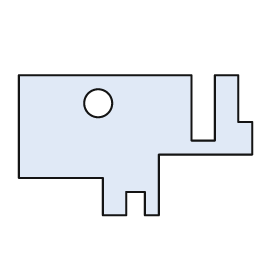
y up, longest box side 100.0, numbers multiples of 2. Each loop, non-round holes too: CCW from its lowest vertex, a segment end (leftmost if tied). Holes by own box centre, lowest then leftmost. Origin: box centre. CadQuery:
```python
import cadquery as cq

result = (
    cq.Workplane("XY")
    .moveTo(-14.0, -30.0)
    .lineTo(-4.0, -30.0)
    .lineTo(-4.0, -20.0)
    .lineTo(4.0, -20.0)
    .lineTo(4.0, -30.0)
    .lineTo(10.0, -30.0)
    .lineTo(10.0, -4.0)
    .lineTo(50.0, -4.0)
    .lineTo(50.0, 10.0)
    .lineTo(44.0, 10.0)
    .lineTo(44.0, 30.0)
    .lineTo(34.0, 30.0)
    .lineTo(34.0, 2.0)
    .lineTo(24.0, 2.0)
    .lineTo(24.0, 30.0)
    .lineTo(-50.0, 30.0)
    .lineTo(-50.0, -14.0)
    .lineTo(-14.0, -14.0)
    .close()
    .moveTo(-16.0, 18.0)
    .circle(6.0)
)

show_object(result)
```